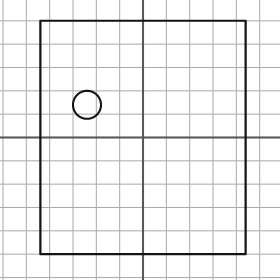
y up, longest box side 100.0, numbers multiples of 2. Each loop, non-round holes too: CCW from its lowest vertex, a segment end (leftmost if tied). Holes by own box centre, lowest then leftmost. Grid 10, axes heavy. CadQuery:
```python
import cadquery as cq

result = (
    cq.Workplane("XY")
    .moveTo(-44.0, -50.0)
    .lineTo(44.0, -50.0)
    .lineTo(44.0, 50.0)
    .lineTo(-44.0, 50.0)
    .close()
    .moveTo(-24.0, 14.0)
    .circle(6.0)
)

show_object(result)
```